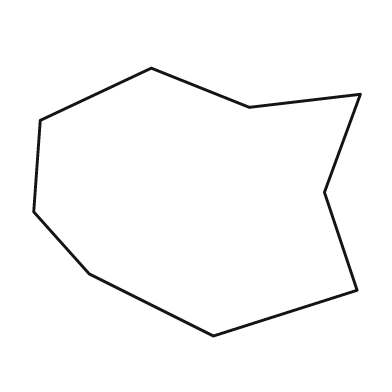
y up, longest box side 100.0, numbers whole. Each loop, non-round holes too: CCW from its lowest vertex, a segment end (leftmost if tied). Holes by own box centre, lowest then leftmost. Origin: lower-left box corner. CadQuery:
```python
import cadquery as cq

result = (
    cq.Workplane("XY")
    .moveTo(55.0, 0.0)
    .lineTo(99.0, 14.0)
    .lineTo(89.0, 44.0)
    .lineTo(100.0, 74.0)
    .lineTo(66.0, 70.0)
    .lineTo(36.0, 82.0)
    .lineTo(2.0, 66.0)
    .lineTo(0.0, 38.0)
    .lineTo(17.0, 19.0)
    .close()
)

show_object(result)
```